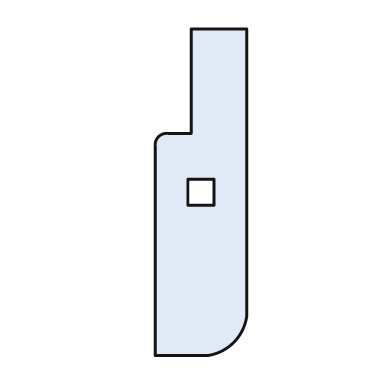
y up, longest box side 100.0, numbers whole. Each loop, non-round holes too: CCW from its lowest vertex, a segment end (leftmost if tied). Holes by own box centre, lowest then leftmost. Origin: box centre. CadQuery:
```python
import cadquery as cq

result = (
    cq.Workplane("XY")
    .moveTo(-14.0, -50.0)
    .lineTo(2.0, -50.0)
    .threePointArc((10.0, -46.0), (14.0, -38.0))
    .lineTo(14.0, 50.0)
    .lineTo(-3.0, 50.0)
    .lineTo(-3.0, 18.0)
    .lineTo(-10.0, 18.0)
    .threePointArc((-13.0, 17.0), (-14.0, 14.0))
    .close()
    .moveTo(-4.0, -4.0)
    .lineTo(4.0, -4.0)
    .lineTo(4.0, 4.0)
    .lineTo(-4.0, 4.0)
    .close()
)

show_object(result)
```